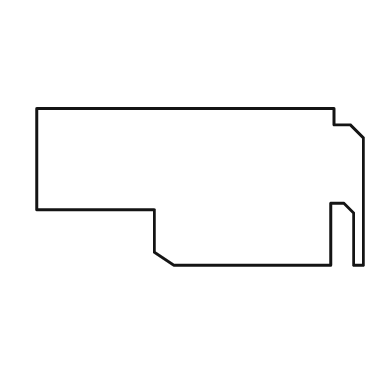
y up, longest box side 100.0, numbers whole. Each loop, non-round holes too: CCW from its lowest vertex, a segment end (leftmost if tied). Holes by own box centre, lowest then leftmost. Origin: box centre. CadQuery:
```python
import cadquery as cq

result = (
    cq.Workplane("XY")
    .moveTo(-8.0, -24.0)
    .lineTo(40.0, -24.0)
    .lineTo(40.0, -5.0)
    .lineTo(44.0, -5.0)
    .lineTo(47.0, -8.0)
    .lineTo(47.0, -24.0)
    .lineTo(50.0, -24.0)
    .lineTo(50.0, 15.0)
    .lineTo(46.0, 19.0)
    .lineTo(41.0, 19.0)
    .lineTo(41.0, 24.0)
    .lineTo(-50.0, 24.0)
    .lineTo(-50.0, -7.0)
    .lineTo(-14.0, -7.0)
    .lineTo(-14.0, -20.0)
    .close()
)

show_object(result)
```